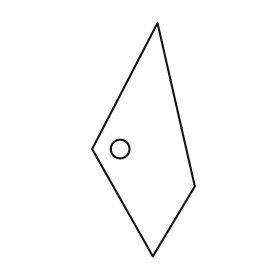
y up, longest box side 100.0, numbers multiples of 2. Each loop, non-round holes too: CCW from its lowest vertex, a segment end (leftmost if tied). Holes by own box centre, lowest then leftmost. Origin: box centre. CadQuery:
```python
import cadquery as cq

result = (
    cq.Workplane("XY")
    .moveTo(4.0, -50.0)
    .lineTo(22.0, -20.0)
    .lineTo(6.0, 50.0)
    .lineTo(-22.0, -4.0)
    .close()
    .moveTo(-10.0, -4.0)
    .circle(4.0)
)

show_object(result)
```